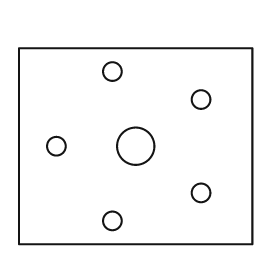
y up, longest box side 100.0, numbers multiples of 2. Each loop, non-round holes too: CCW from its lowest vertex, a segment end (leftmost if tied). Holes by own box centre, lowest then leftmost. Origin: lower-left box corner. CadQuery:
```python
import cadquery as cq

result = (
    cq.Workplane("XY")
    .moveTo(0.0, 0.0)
    .lineTo(100.0, 0.0)
    .lineTo(100.0, 84.0)
    .lineTo(0.0, 84.0)
    .close()
    .moveTo(40.0, 10.0)
    .circle(4.0)
    .moveTo(78.0, 22.0)
    .circle(4.0)
    .moveTo(16.0, 42.0)
    .circle(4.0)
    .moveTo(50.0, 42.0)
    .circle(8.0)
    .moveTo(78.0, 62.0)
    .circle(4.0)
    .moveTo(40.0, 74.0)
    .circle(4.0)
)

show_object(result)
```